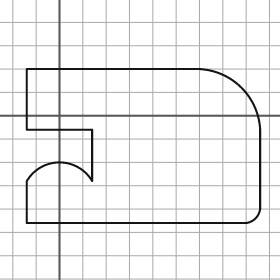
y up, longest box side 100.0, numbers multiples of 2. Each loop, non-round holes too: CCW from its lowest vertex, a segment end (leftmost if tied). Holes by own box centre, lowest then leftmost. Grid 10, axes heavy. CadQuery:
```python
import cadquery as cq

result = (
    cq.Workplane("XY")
    .moveTo(-14.0, -46.0)
    .lineTo(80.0, -46.0)
    .threePointArc((84.0, -44.0), (86.0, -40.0))
    .lineTo(86.0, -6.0)
    .threePointArc((78.0, 12.0), (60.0, 20.0))
    .lineTo(-14.0, 20.0)
    .lineTo(-14.0, -6.0)
    .lineTo(14.0, -6.0)
    .lineTo(14.0, -28.0)
    .threePointArc((0.0, -20.0), (-14.0, -28.0))
    .close()
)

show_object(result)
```